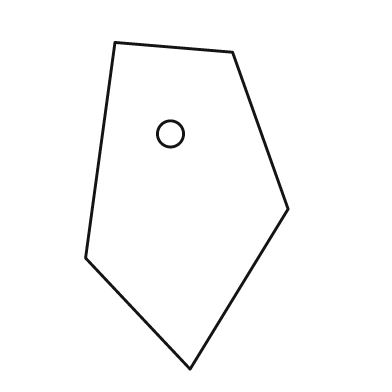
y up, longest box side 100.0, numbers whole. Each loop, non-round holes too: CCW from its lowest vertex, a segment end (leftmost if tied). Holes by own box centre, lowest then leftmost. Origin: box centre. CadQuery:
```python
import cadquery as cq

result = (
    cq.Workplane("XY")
    .moveTo(1.0, -50.0)
    .lineTo(31.0, -1.0)
    .lineTo(14.0, 47.0)
    .lineTo(-22.0, 50.0)
    .lineTo(-31.0, -16.0)
    .close()
    .moveTo(-5.0, 22.0)
    .circle(4.0)
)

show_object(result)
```